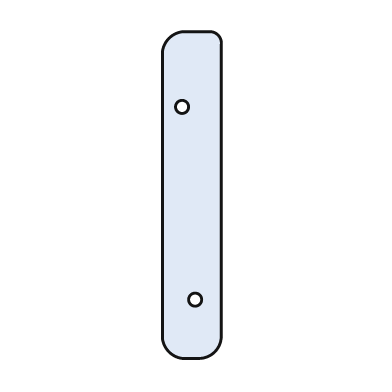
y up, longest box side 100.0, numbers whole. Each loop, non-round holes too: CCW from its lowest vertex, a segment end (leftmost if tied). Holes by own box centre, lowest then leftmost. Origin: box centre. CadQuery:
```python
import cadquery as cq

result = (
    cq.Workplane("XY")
    .moveTo(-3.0, -50.0)
    .lineTo(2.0, -50.0)
    .threePointArc((7.0, -48.0), (9.0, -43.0))
    .lineTo(9.0, 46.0)
    .threePointArc((8.0, 49.0), (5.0, 50.0))
    .lineTo(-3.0, 50.0)
    .threePointArc((-7.0, 48.0), (-9.0, 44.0))
    .lineTo(-9.0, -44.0)
    .threePointArc((-7.0, -48.0), (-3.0, -50.0))
    .close()
    .moveTo(1.0, -32.0)
    .circle(2.0)
    .moveTo(-3.0, 27.0)
    .circle(2.0)
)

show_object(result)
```